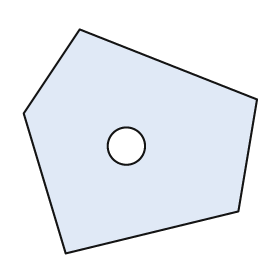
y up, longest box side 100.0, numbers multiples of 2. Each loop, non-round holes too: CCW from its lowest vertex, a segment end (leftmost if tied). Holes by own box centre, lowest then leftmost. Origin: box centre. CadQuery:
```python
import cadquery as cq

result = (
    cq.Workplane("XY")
    .moveTo(-32.0, -48.0)
    .lineTo(42.0, -30.0)
    .lineTo(50.0, 18.0)
    .lineTo(-26.0, 48.0)
    .lineTo(-50.0, 12.0)
    .close()
    .moveTo(-6.0, -2.0)
    .circle(8.0)
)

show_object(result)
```